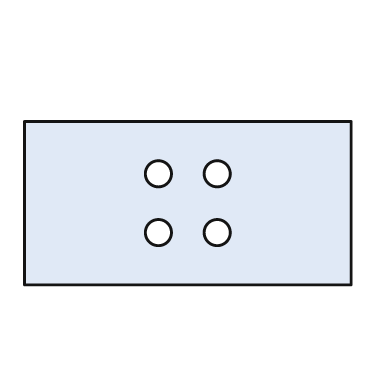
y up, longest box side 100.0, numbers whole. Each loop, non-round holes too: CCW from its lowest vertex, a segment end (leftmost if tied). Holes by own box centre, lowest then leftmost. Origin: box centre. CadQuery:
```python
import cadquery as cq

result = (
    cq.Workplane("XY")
    .moveTo(-50.0, -25.0)
    .lineTo(50.0, -25.0)
    .lineTo(50.0, 25.0)
    .lineTo(-50.0, 25.0)
    .close()
    .moveTo(-9.0, -9.0)
    .circle(4.0)
    .moveTo(9.0, -9.0)
    .circle(4.0)
    .moveTo(-9.0, 9.0)
    .circle(4.0)
    .moveTo(9.0, 9.0)
    .circle(4.0)
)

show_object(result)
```